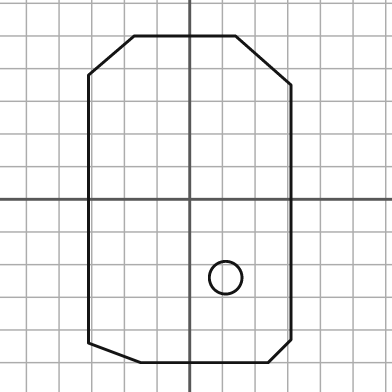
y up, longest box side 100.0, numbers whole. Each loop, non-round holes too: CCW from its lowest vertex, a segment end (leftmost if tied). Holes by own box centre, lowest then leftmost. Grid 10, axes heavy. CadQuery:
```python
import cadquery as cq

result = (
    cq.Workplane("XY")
    .moveTo(-15.0, -50.0)
    .lineTo(24.0, -50.0)
    .lineTo(31.0, -43.0)
    .lineTo(31.0, 35.0)
    .lineTo(14.0, 50.0)
    .lineTo(-17.0, 50.0)
    .lineTo(-31.0, 38.0)
    .lineTo(-31.0, -44.0)
    .close()
    .moveTo(11.0, -24.0)
    .circle(5.0)
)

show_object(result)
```